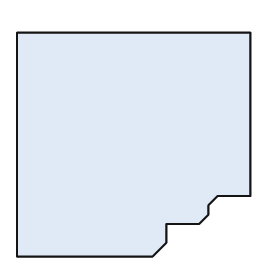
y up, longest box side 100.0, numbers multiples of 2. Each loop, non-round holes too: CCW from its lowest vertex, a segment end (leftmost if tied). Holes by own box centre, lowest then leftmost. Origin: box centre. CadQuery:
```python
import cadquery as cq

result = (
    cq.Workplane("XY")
    .moveTo(-50.0, -48.0)
    .lineTo(8.0, -48.0)
    .lineTo(14.0, -42.0)
    .lineTo(14.0, -34.0)
    .lineTo(28.0, -34.0)
    .lineTo(32.0, -30.0)
    .lineTo(32.0, -26.0)
    .lineTo(36.0, -22.0)
    .lineTo(50.0, -22.0)
    .lineTo(50.0, 48.0)
    .lineTo(-50.0, 48.0)
    .close()
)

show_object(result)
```